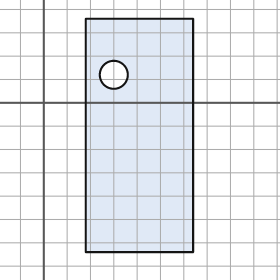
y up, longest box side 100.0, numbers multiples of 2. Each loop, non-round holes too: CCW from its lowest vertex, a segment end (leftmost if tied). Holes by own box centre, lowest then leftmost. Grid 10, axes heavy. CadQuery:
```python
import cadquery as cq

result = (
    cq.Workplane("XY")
    .moveTo(18.0, -64.0)
    .lineTo(64.0, -64.0)
    .lineTo(64.0, 36.0)
    .lineTo(18.0, 36.0)
    .close()
    .moveTo(30.0, 12.0)
    .circle(6.0)
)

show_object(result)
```